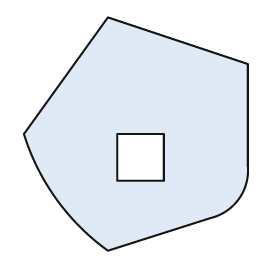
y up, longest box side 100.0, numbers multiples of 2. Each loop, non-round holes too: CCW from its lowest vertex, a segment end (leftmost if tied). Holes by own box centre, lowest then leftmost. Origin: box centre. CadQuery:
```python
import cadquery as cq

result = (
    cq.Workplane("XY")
    .moveTo(-12.0, -50.0)
    .lineTo(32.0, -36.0)
    .threePointArc((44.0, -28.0), (48.0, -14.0))
    .lineTo(48.0, 30.0)
    .lineTo(-12.0, 50.0)
    .lineTo(-48.0, 0.0)
    .threePointArc((-34.0, -28.0), (-12.0, -50.0))
    .close()
    .moveTo(-8.0, -20.0)
    .lineTo(12.0, -20.0)
    .lineTo(12.0, 0.0)
    .lineTo(-8.0, 0.0)
    .close()
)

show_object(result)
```